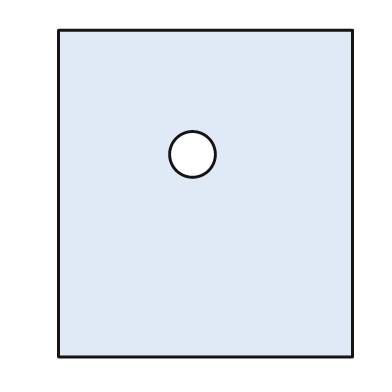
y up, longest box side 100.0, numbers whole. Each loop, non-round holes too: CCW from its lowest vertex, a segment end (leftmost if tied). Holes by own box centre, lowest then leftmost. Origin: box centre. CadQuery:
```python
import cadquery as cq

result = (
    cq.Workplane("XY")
    .moveTo(-45.0, -50.0)
    .lineTo(45.0, -50.0)
    .lineTo(45.0, 50.0)
    .lineTo(-45.0, 50.0)
    .close()
    .moveTo(-4.0, 12.0)
    .circle(7.0)
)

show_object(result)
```